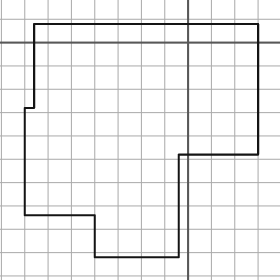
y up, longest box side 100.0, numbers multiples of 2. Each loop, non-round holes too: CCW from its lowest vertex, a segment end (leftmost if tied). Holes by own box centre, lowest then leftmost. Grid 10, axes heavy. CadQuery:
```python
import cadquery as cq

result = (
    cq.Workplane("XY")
    .moveTo(-40.0, -92.0)
    .lineTo(-4.0, -92.0)
    .lineTo(-4.0, -48.0)
    .lineTo(30.0, -48.0)
    .lineTo(30.0, 8.0)
    .lineTo(-66.0, 8.0)
    .lineTo(-66.0, -28.0)
    .lineTo(-70.0, -28.0)
    .lineTo(-70.0, -74.0)
    .lineTo(-40.0, -74.0)
    .close()
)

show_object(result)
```